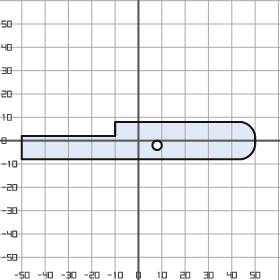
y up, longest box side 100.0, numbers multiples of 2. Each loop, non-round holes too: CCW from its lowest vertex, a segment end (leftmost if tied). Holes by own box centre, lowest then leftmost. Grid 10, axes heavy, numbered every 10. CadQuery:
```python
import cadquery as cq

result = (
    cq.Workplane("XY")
    .moveTo(-50.0, -8.0)
    .lineTo(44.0, -8.0)
    .threePointArc((48.0, -6.0), (50.0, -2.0))
    .lineTo(50.0, 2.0)
    .threePointArc((48.0, 6.0), (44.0, 8.0))
    .lineTo(-10.0, 8.0)
    .lineTo(-10.0, 2.0)
    .lineTo(-50.0, 2.0)
    .close()
    .moveTo(8.0, -2.0)
    .circle(2.0)
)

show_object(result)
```